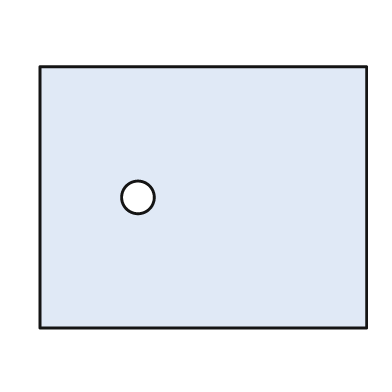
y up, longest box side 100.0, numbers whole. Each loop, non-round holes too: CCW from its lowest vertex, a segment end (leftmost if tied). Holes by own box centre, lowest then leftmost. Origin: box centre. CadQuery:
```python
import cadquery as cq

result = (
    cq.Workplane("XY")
    .moveTo(-50.0, -40.0)
    .lineTo(50.0, -40.0)
    .lineTo(50.0, 40.0)
    .lineTo(-50.0, 40.0)
    .close()
    .moveTo(-20.0, 0.0)
    .circle(5.0)
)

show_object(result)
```